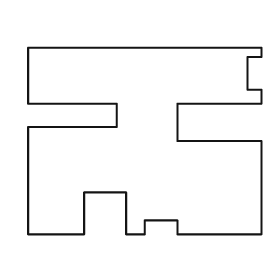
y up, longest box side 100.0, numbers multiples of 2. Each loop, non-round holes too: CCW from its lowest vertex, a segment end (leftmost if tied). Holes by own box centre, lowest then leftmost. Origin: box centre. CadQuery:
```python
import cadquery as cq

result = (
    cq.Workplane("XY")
    .moveTo(-50.0, -40.0)
    .lineTo(-26.0, -40.0)
    .lineTo(-26.0, -22.0)
    .lineTo(-8.0, -22.0)
    .lineTo(-8.0, -40.0)
    .lineTo(0.0, -40.0)
    .lineTo(0.0, -34.0)
    .lineTo(14.0, -34.0)
    .lineTo(14.0, -40.0)
    .lineTo(50.0, -40.0)
    .lineTo(50.0, 0.0)
    .lineTo(14.0, 0.0)
    .lineTo(14.0, 16.0)
    .lineTo(50.0, 16.0)
    .lineTo(50.0, 22.0)
    .lineTo(44.0, 22.0)
    .lineTo(44.0, 36.0)
    .lineTo(50.0, 36.0)
    .lineTo(50.0, 40.0)
    .lineTo(-50.0, 40.0)
    .lineTo(-50.0, 16.0)
    .lineTo(-12.0, 16.0)
    .lineTo(-12.0, 6.0)
    .lineTo(-50.0, 6.0)
    .close()
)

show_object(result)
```